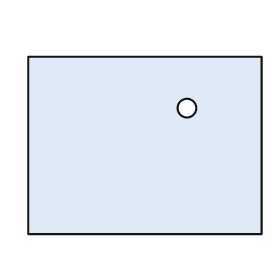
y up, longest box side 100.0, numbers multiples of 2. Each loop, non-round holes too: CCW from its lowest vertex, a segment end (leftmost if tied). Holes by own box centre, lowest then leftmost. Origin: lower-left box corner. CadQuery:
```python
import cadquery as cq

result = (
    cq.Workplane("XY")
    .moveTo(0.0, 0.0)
    .lineTo(100.0, 0.0)
    .lineTo(100.0, 76.0)
    .lineTo(0.0, 76.0)
    .close()
    .moveTo(68.0, 54.0)
    .circle(4.0)
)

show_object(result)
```